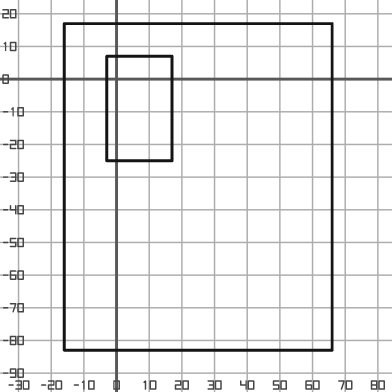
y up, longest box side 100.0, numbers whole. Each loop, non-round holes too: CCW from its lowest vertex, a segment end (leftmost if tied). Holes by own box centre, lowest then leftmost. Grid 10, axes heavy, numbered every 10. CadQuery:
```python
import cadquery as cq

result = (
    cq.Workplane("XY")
    .moveTo(-16.0, -83.0)
    .lineTo(66.0, -83.0)
    .lineTo(66.0, 17.0)
    .lineTo(-16.0, 17.0)
    .close()
    .moveTo(-3.0, -25.0)
    .lineTo(17.0, -25.0)
    .lineTo(17.0, 7.0)
    .lineTo(-3.0, 7.0)
    .close()
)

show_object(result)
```